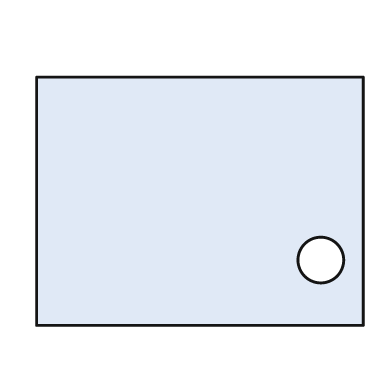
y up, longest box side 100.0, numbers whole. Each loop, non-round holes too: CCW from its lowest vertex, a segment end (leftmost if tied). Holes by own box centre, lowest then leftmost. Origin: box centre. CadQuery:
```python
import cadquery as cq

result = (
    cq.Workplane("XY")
    .moveTo(-50.0, -38.0)
    .lineTo(50.0, -38.0)
    .lineTo(50.0, 38.0)
    .lineTo(-50.0, 38.0)
    .close()
    .moveTo(37.0, -18.0)
    .circle(7.0)
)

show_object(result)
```